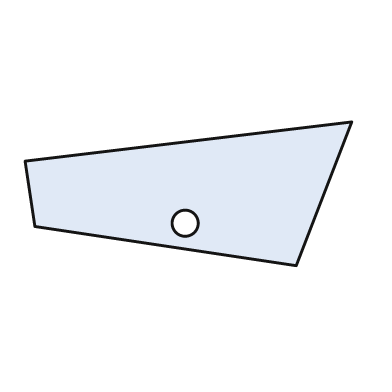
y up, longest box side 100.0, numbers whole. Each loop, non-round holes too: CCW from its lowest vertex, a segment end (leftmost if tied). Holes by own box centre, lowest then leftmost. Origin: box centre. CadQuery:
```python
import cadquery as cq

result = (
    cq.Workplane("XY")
    .moveTo(33.0, -22.0)
    .lineTo(50.0, 22.0)
    .lineTo(-50.0, 10.0)
    .lineTo(-47.0, -10.0)
    .close()
    .moveTo(-1.0, -9.0)
    .circle(4.0)
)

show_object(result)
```